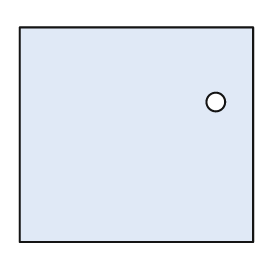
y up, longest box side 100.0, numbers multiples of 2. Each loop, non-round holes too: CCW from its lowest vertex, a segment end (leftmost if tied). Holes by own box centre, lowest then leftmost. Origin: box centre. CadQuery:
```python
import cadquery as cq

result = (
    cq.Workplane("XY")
    .moveTo(-50.0, -46.0)
    .lineTo(50.0, -46.0)
    .lineTo(50.0, 46.0)
    .lineTo(-50.0, 46.0)
    .close()
    .moveTo(34.0, 14.0)
    .circle(4.0)
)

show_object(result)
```